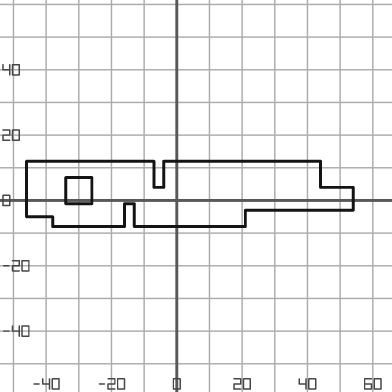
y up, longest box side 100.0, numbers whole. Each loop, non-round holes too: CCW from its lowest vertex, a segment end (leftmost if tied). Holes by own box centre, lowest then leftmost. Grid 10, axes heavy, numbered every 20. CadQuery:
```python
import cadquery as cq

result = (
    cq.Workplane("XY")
    .moveTo(-38.0, -8.0)
    .lineTo(-16.0, -8.0)
    .lineTo(-16.0, -1.0)
    .lineTo(-13.0, -1.0)
    .lineTo(-13.0, -8.0)
    .lineTo(21.0, -8.0)
    .lineTo(21.0, -3.0)
    .lineTo(54.0, -3.0)
    .lineTo(54.0, 4.0)
    .lineTo(44.0, 4.0)
    .lineTo(44.0, 12.0)
    .lineTo(-4.0, 12.0)
    .lineTo(-4.0, 4.0)
    .lineTo(-7.0, 4.0)
    .lineTo(-7.0, 12.0)
    .lineTo(-46.0, 12.0)
    .lineTo(-46.0, -5.0)
    .lineTo(-38.0, -5.0)
    .close()
    .moveTo(-34.0, -1.0)
    .lineTo(-26.0, -1.0)
    .lineTo(-26.0, 7.0)
    .lineTo(-34.0, 7.0)
    .close()
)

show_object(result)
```